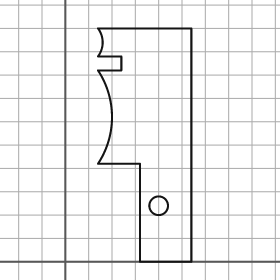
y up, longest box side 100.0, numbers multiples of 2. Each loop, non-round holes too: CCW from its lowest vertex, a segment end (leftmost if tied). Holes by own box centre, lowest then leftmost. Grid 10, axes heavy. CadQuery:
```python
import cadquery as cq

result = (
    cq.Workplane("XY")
    .moveTo(32.0, 0.0)
    .lineTo(54.0, 0.0)
    .lineTo(54.0, 100.0)
    .lineTo(14.0, 100.0)
    .threePointArc((16.0, 94.0), (14.0, 88.0))
    .lineTo(24.0, 88.0)
    .lineTo(24.0, 82.0)
    .lineTo(14.0, 82.0)
    .threePointArc((20.0, 62.0), (14.0, 42.0))
    .lineTo(32.0, 42.0)
    .close()
    .moveTo(40.0, 24.0)
    .circle(4.0)
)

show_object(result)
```